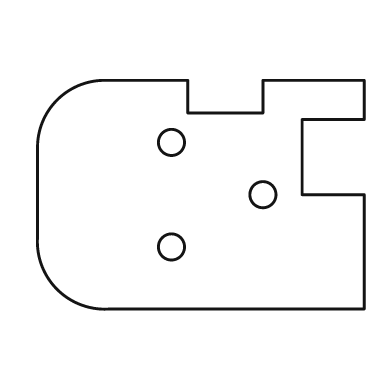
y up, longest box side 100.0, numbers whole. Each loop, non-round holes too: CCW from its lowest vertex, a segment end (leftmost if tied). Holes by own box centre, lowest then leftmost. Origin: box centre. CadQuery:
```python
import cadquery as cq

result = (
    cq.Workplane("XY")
    .moveTo(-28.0, -35.0)
    .lineTo(50.0, -35.0)
    .lineTo(50.0, 0.0)
    .lineTo(31.0, 0.0)
    .lineTo(31.0, 23.0)
    .lineTo(50.0, 23.0)
    .lineTo(50.0, 35.0)
    .lineTo(19.0, 35.0)
    .lineTo(19.0, 25.0)
    .lineTo(-4.0, 25.0)
    .lineTo(-4.0, 35.0)
    .lineTo(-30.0, 35.0)
    .threePointArc((-44.0, 29.0), (-50.0, 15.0))
    .lineTo(-50.0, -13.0)
    .threePointArc((-44.0, -29.0), (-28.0, -35.0))
    .close()
    .moveTo(-9.0, -16.0)
    .circle(4.0)
    .moveTo(19.0, 0.0)
    .circle(4.0)
    .moveTo(-9.0, 16.0)
    .circle(4.0)
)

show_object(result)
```